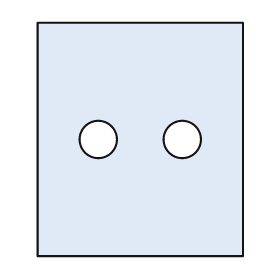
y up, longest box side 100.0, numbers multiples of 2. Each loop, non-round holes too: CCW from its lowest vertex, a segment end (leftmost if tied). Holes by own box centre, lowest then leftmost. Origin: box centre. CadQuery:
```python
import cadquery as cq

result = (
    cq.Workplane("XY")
    .moveTo(-44.0, -50.0)
    .lineTo(44.0, -50.0)
    .lineTo(44.0, 50.0)
    .lineTo(-44.0, 50.0)
    .close()
    .moveTo(-18.0, 0.0)
    .circle(8.0)
    .moveTo(18.0, 0.0)
    .circle(8.0)
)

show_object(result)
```